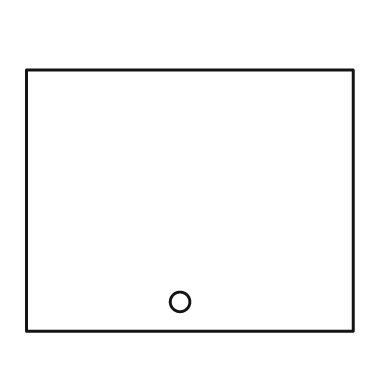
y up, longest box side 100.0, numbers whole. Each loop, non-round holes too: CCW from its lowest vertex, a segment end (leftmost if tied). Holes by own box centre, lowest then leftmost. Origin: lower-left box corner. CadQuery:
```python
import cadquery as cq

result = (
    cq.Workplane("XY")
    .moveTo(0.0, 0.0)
    .lineTo(100.0, 0.0)
    .lineTo(100.0, 80.0)
    .lineTo(0.0, 80.0)
    .close()
    .moveTo(47.0, 9.0)
    .circle(3.0)
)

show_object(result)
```